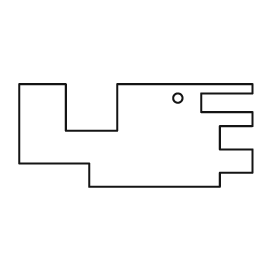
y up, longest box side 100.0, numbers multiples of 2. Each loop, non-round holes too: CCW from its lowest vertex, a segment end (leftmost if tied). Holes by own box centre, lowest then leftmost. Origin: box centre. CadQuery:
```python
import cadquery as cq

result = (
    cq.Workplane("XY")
    .moveTo(-20.0, -22.0)
    .lineTo(36.0, -22.0)
    .lineTo(36.0, -16.0)
    .lineTo(50.0, -16.0)
    .lineTo(50.0, -6.0)
    .lineTo(36.0, -6.0)
    .lineTo(36.0, 4.0)
    .lineTo(50.0, 4.0)
    .lineTo(50.0, 10.0)
    .lineTo(28.0, 10.0)
    .lineTo(28.0, 18.0)
    .lineTo(50.0, 18.0)
    .lineTo(50.0, 22.0)
    .lineTo(-8.0, 22.0)
    .lineTo(-8.0, 2.0)
    .lineTo(-30.0, 2.0)
    .lineTo(-30.0, 22.0)
    .lineTo(-50.0, 22.0)
    .lineTo(-50.0, -12.0)
    .lineTo(-20.0, -12.0)
    .close()
    .moveTo(18.0, 16.0)
    .circle(2.0)
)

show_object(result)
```